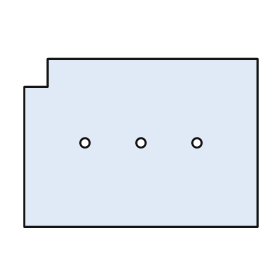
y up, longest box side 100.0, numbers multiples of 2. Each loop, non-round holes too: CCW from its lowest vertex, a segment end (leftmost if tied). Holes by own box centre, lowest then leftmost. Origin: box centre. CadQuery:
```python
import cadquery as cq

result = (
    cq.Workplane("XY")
    .moveTo(-50.0, -36.0)
    .lineTo(50.0, -36.0)
    .lineTo(50.0, 36.0)
    .lineTo(-40.0, 36.0)
    .lineTo(-40.0, 24.0)
    .lineTo(-50.0, 24.0)
    .close()
    .moveTo(-24.0, 0.0)
    .circle(2.0)
    .moveTo(0.0, 0.0)
    .circle(2.0)
    .moveTo(24.0, 0.0)
    .circle(2.0)
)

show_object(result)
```